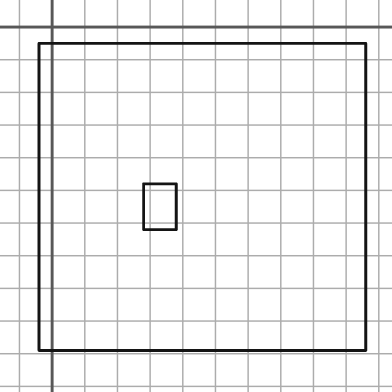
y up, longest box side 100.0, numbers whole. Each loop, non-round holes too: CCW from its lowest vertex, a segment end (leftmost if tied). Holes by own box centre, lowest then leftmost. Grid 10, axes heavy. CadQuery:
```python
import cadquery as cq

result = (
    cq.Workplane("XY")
    .moveTo(-4.0, -99.0)
    .lineTo(96.0, -99.0)
    .lineTo(96.0, -5.0)
    .lineTo(-4.0, -5.0)
    .close()
    .moveTo(28.0, -62.0)
    .lineTo(38.0, -62.0)
    .lineTo(38.0, -48.0)
    .lineTo(28.0, -48.0)
    .close()
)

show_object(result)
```